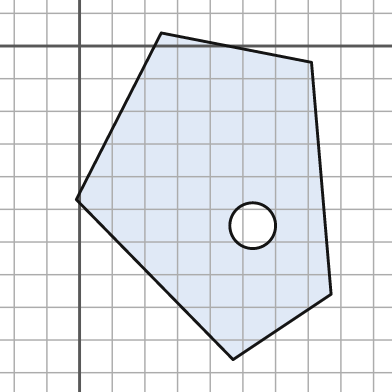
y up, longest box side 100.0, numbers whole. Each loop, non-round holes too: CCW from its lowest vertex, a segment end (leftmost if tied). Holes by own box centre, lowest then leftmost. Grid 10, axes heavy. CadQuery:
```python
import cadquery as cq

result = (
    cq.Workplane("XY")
    .moveTo(47.0, -96.0)
    .lineTo(77.0, -76.0)
    .lineTo(71.0, -5.0)
    .lineTo(25.0, 4.0)
    .lineTo(-1.0, -47.0)
    .close()
    .moveTo(53.0, -55.0)
    .circle(7.0)
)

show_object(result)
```